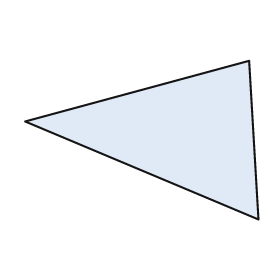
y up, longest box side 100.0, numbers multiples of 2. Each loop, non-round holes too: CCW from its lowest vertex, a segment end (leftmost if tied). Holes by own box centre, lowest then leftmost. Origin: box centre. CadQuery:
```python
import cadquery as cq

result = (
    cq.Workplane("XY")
    .moveTo(50.0, -34.0)
    .lineTo(46.0, 34.0)
    .lineTo(-50.0, 8.0)
    .close()
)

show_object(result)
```